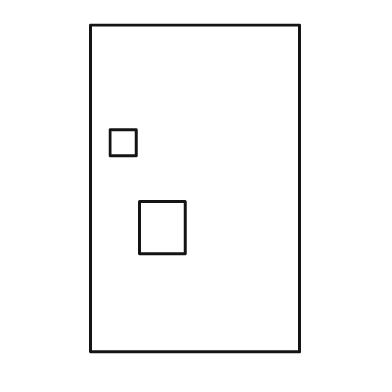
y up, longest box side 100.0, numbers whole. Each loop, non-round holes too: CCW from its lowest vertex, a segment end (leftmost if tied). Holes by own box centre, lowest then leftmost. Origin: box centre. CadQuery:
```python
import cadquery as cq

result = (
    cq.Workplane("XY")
    .moveTo(-32.0, -50.0)
    .lineTo(32.0, -50.0)
    .lineTo(32.0, 50.0)
    .lineTo(-32.0, 50.0)
    .close()
    .moveTo(-17.0, -20.0)
    .lineTo(-3.0, -20.0)
    .lineTo(-3.0, -4.0)
    .lineTo(-17.0, -4.0)
    .close()
    .moveTo(-26.0, 10.0)
    .lineTo(-18.0, 10.0)
    .lineTo(-18.0, 18.0)
    .lineTo(-26.0, 18.0)
    .close()
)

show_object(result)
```